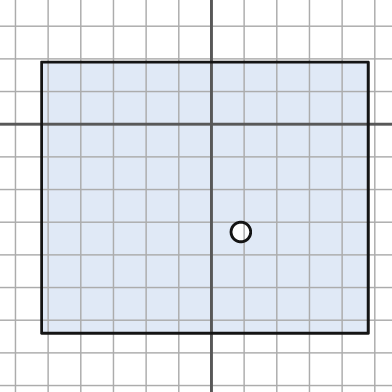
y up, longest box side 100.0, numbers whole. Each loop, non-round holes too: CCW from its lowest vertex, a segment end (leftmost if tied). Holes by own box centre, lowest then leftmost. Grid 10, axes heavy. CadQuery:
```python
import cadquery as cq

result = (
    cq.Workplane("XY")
    .moveTo(-52.0, -64.0)
    .lineTo(48.0, -64.0)
    .lineTo(48.0, 19.0)
    .lineTo(-52.0, 19.0)
    .close()
    .moveTo(9.0, -33.0)
    .circle(3.0)
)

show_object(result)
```